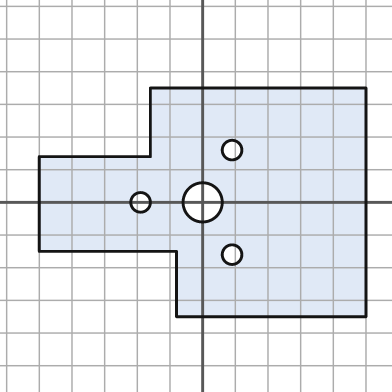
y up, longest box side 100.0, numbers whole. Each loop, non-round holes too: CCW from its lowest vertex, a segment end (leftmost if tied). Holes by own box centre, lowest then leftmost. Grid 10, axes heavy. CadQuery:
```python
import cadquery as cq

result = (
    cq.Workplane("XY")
    .moveTo(-8.0, -35.0)
    .lineTo(50.0, -35.0)
    .lineTo(50.0, 35.0)
    .lineTo(-16.0, 35.0)
    .lineTo(-16.0, 14.0)
    .lineTo(-50.0, 14.0)
    .lineTo(-50.0, -15.0)
    .lineTo(-8.0, -15.0)
    .close()
    .moveTo(9.0, -16.0)
    .circle(3.0)
    .moveTo(-19.0, 0.0)
    .circle(3.0)
    .moveTo(0.0, 0.0)
    .circle(6.0)
    .moveTo(9.0, 16.0)
    .circle(3.0)
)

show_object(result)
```